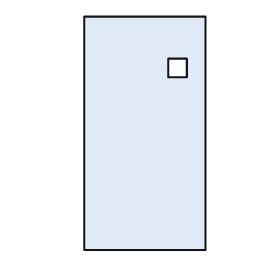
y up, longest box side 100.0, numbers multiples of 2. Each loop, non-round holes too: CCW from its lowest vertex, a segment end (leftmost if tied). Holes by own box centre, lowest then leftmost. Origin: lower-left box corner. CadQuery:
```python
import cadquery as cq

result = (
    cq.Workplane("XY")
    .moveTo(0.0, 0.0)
    .lineTo(52.0, 0.0)
    .lineTo(52.0, 100.0)
    .lineTo(0.0, 100.0)
    .close()
    .moveTo(36.0, 74.0)
    .lineTo(44.0, 74.0)
    .lineTo(44.0, 82.0)
    .lineTo(36.0, 82.0)
    .close()
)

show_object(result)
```